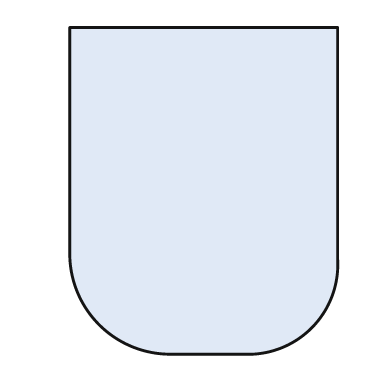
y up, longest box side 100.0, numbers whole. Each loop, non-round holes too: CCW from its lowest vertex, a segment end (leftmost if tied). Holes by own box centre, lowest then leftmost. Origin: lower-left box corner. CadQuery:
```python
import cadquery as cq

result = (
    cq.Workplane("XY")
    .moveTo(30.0, 0.0)
    .lineTo(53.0, 0.0)
    .threePointArc((74.0, 8.0), (82.0, 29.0))
    .lineTo(82.0, 100.0)
    .lineTo(0.0, 100.0)
    .lineTo(0.0, 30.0)
    .threePointArc((9.0, 9.0), (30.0, 0.0))
    .close()
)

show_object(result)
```